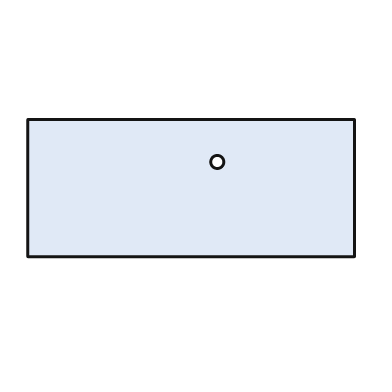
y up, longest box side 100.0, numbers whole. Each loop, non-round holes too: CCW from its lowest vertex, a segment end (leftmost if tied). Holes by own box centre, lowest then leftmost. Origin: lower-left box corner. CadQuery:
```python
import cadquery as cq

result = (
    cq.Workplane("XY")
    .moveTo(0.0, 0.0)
    .lineTo(100.0, 0.0)
    .lineTo(100.0, 42.0)
    .lineTo(0.0, 42.0)
    .close()
    .moveTo(58.0, 29.0)
    .circle(2.0)
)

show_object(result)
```